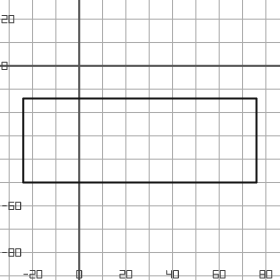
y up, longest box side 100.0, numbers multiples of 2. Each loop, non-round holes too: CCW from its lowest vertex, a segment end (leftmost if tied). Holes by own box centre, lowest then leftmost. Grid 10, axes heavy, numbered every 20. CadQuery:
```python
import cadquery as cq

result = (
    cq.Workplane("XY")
    .moveTo(-24.0, -50.0)
    .lineTo(76.0, -50.0)
    .lineTo(76.0, -14.0)
    .lineTo(-24.0, -14.0)
    .close()
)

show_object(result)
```